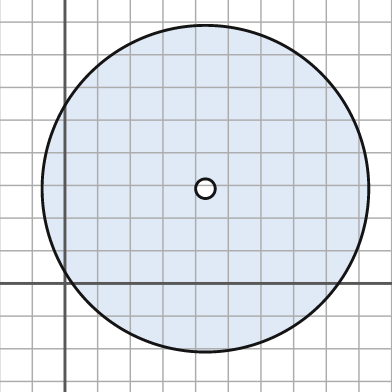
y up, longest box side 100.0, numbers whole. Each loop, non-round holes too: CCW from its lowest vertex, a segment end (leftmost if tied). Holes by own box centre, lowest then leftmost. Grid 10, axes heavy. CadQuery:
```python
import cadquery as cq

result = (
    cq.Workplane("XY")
    .moveTo(43.0, 29.0)
    .circle(50.0)
    .moveTo(43.0, 29.0)
    .circle(3.0)
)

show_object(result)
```